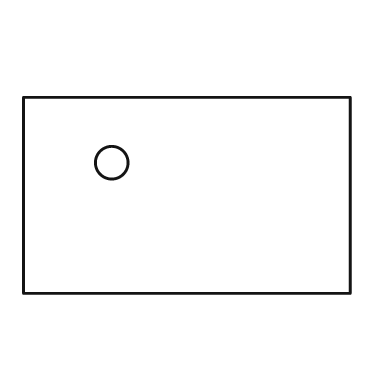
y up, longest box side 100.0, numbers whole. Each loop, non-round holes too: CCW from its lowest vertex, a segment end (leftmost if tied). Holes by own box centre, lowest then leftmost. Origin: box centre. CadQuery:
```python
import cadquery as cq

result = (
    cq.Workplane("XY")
    .moveTo(-50.0, -30.0)
    .lineTo(50.0, -30.0)
    .lineTo(50.0, 30.0)
    .lineTo(-50.0, 30.0)
    .close()
    .moveTo(-23.0, 10.0)
    .circle(5.0)
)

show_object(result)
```